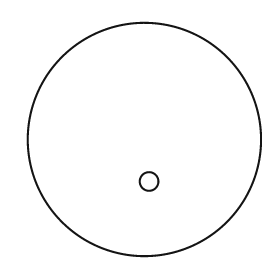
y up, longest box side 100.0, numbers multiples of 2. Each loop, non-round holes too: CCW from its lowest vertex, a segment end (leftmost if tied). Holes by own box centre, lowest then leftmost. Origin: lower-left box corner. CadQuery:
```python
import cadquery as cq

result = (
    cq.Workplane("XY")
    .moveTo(50.0, 50.0)
    .circle(50.0)
    .moveTo(52.0, 32.0)
    .circle(4.0)
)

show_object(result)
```